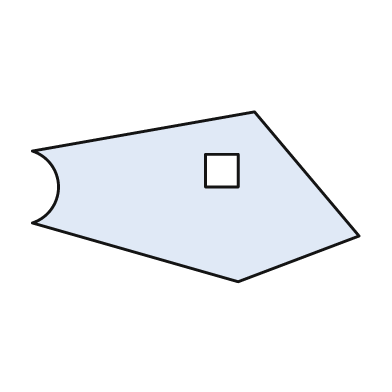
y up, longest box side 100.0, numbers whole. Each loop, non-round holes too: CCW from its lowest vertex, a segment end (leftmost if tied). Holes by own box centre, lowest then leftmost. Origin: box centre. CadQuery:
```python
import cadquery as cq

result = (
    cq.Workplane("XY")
    .moveTo(13.0, -26.0)
    .lineTo(50.0, -12.0)
    .lineTo(18.0, 26.0)
    .lineTo(-50.0, 14.0)
    .threePointArc((-42.0, 3.0), (-50.0, -8.0))
    .close()
    .moveTo(3.0, 3.0)
    .lineTo(13.0, 3.0)
    .lineTo(13.0, 13.0)
    .lineTo(3.0, 13.0)
    .close()
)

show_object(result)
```